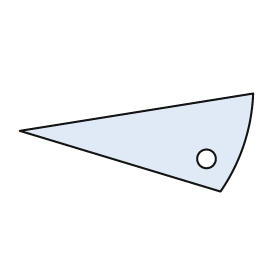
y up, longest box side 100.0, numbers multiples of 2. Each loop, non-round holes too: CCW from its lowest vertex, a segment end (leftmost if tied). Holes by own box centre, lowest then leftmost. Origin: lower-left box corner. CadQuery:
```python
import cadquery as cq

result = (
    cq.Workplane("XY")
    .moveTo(86.0, 0.0)
    .threePointArc((96.0, 20.0), (100.0, 42.0))
    .lineTo(0.0, 26.0)
    .close()
    .moveTo(80.0, 14.0)
    .circle(4.0)
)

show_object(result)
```